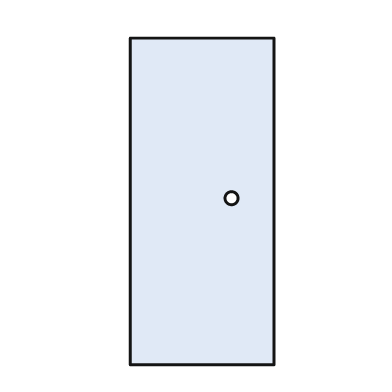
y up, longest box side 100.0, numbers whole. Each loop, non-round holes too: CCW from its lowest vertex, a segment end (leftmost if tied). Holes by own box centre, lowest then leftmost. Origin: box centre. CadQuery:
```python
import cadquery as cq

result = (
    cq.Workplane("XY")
    .moveTo(-22.0, -50.0)
    .lineTo(22.0, -50.0)
    .lineTo(22.0, 50.0)
    .lineTo(-22.0, 50.0)
    .close()
    .moveTo(9.0, 1.0)
    .circle(2.0)
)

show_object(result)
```